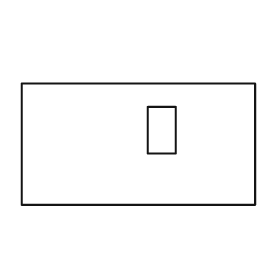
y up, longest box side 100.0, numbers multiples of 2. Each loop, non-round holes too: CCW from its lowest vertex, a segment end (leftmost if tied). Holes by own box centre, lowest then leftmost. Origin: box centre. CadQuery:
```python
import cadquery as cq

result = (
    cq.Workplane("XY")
    .moveTo(-50.0, -26.0)
    .lineTo(50.0, -26.0)
    .lineTo(50.0, 26.0)
    .lineTo(-50.0, 26.0)
    .close()
    .moveTo(4.0, -4.0)
    .lineTo(16.0, -4.0)
    .lineTo(16.0, 16.0)
    .lineTo(4.0, 16.0)
    .close()
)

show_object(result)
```